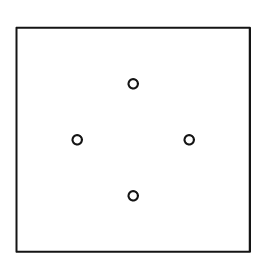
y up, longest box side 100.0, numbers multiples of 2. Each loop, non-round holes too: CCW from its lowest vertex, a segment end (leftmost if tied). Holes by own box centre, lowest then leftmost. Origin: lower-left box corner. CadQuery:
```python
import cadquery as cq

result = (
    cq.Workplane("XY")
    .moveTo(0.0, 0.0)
    .lineTo(100.0, 0.0)
    .lineTo(100.0, 96.0)
    .lineTo(0.0, 96.0)
    .close()
    .moveTo(50.0, 24.0)
    .circle(2.0)
    .moveTo(26.0, 48.0)
    .circle(2.0)
    .moveTo(74.0, 48.0)
    .circle(2.0)
    .moveTo(50.0, 72.0)
    .circle(2.0)
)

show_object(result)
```